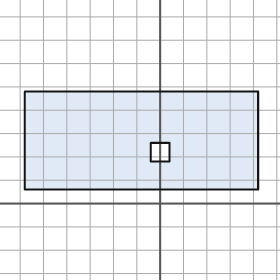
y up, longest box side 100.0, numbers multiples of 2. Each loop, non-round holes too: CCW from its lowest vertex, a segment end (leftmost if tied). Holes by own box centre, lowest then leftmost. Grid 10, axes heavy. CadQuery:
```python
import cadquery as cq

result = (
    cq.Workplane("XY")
    .moveTo(-58.0, 6.0)
    .lineTo(42.0, 6.0)
    .lineTo(42.0, 48.0)
    .lineTo(-58.0, 48.0)
    .close()
    .moveTo(-4.0, 18.0)
    .lineTo(4.0, 18.0)
    .lineTo(4.0, 26.0)
    .lineTo(-4.0, 26.0)
    .close()
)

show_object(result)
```